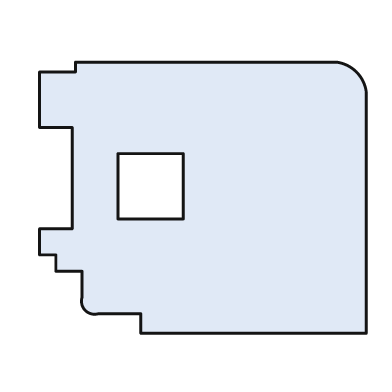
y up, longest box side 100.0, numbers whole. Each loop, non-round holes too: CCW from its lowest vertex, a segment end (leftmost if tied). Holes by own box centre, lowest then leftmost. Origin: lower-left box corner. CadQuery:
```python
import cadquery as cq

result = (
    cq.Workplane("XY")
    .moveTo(31.0, 0.0)
    .lineTo(100.0, 0.0)
    .lineTo(100.0, 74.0)
    .threePointArc((97.0, 80.0), (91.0, 83.0))
    .lineTo(11.0, 83.0)
    .lineTo(11.0, 80.0)
    .lineTo(0.0, 80.0)
    .lineTo(0.0, 63.0)
    .lineTo(10.0, 63.0)
    .lineTo(10.0, 32.0)
    .lineTo(0.0, 32.0)
    .lineTo(0.0, 24.0)
    .lineTo(5.0, 24.0)
    .lineTo(5.0, 19.0)
    .lineTo(13.0, 19.0)
    .lineTo(13.0, 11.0)
    .threePointArc((14.0, 7.0), (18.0, 6.0))
    .lineTo(31.0, 6.0)
    .close()
    .moveTo(24.0, 35.0)
    .lineTo(44.0, 35.0)
    .lineTo(44.0, 55.0)
    .lineTo(24.0, 55.0)
    .close()
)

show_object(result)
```